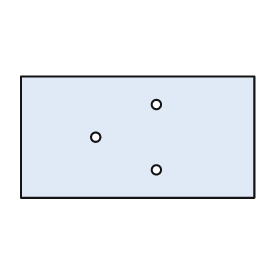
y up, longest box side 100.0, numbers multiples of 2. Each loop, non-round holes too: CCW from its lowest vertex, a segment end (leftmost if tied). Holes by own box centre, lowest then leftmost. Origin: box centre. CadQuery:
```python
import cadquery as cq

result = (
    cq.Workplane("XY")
    .moveTo(-50.0, -26.0)
    .lineTo(50.0, -26.0)
    .lineTo(50.0, 26.0)
    .lineTo(-50.0, 26.0)
    .close()
    .moveTo(8.0, -14.0)
    .circle(2.0)
    .moveTo(-18.0, 0.0)
    .circle(2.0)
    .moveTo(8.0, 14.0)
    .circle(2.0)
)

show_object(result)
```